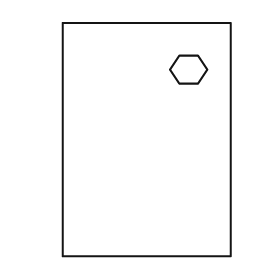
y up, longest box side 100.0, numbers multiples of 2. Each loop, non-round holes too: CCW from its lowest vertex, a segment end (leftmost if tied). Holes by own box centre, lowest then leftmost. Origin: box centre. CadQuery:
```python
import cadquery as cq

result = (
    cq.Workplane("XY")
    .moveTo(-36.0, -50.0)
    .lineTo(36.0, -50.0)
    .lineTo(36.0, 50.0)
    .lineTo(-36.0, 50.0)
    .close()
    .moveTo(14.0, 24.0)
    .lineTo(22.0, 24.0)
    .lineTo(26.0, 30.0)
    .lineTo(22.0, 36.0)
    .lineTo(14.0, 36.0)
    .lineTo(10.0, 30.0)
    .close()
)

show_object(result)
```